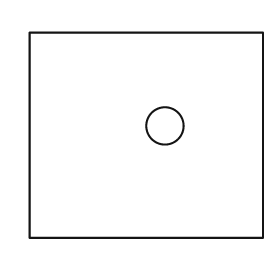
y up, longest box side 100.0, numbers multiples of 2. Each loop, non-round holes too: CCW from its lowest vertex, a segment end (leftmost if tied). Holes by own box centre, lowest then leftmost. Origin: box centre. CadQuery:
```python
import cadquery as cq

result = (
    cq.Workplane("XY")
    .moveTo(-50.0, -44.0)
    .lineTo(50.0, -44.0)
    .lineTo(50.0, 44.0)
    .lineTo(-50.0, 44.0)
    .close()
    .moveTo(8.0, 4.0)
    .circle(8.0)
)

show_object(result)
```